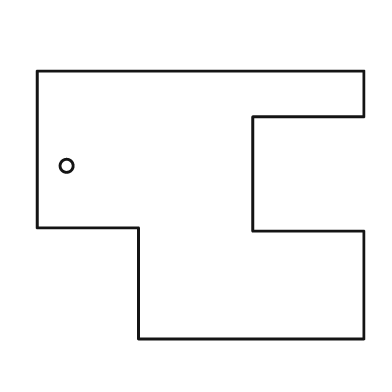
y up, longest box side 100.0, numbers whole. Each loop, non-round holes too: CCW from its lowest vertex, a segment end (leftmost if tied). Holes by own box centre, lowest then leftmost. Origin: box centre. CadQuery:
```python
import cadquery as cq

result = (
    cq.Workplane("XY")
    .moveTo(-19.0, -41.0)
    .lineTo(50.0, -41.0)
    .lineTo(50.0, -8.0)
    .lineTo(16.0, -8.0)
    .lineTo(16.0, 27.0)
    .lineTo(50.0, 27.0)
    .lineTo(50.0, 41.0)
    .lineTo(-50.0, 41.0)
    .lineTo(-50.0, -7.0)
    .lineTo(-19.0, -7.0)
    .close()
    .moveTo(-41.0, 12.0)
    .circle(2.0)
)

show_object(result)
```